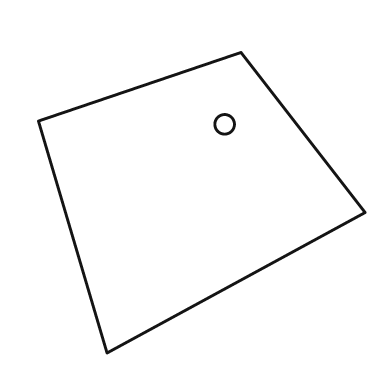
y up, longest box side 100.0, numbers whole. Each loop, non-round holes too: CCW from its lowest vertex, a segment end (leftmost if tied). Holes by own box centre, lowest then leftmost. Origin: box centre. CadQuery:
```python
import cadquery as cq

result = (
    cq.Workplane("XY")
    .moveTo(-29.0, -46.0)
    .lineTo(50.0, -3.0)
    .lineTo(12.0, 46.0)
    .lineTo(-50.0, 25.0)
    .close()
    .moveTo(7.0, 24.0)
    .circle(3.0)
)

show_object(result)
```